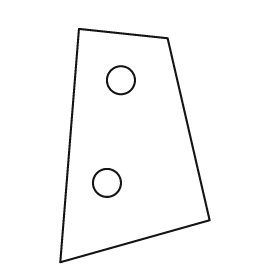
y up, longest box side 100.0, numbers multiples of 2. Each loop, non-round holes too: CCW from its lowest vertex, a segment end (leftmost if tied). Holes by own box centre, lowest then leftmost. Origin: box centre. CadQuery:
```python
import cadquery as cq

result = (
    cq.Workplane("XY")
    .moveTo(-32.0, -50.0)
    .lineTo(32.0, -32.0)
    .lineTo(14.0, 46.0)
    .lineTo(-24.0, 50.0)
    .close()
    .moveTo(-12.0, -16.0)
    .circle(6.0)
    .moveTo(-6.0, 28.0)
    .circle(6.0)
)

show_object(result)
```